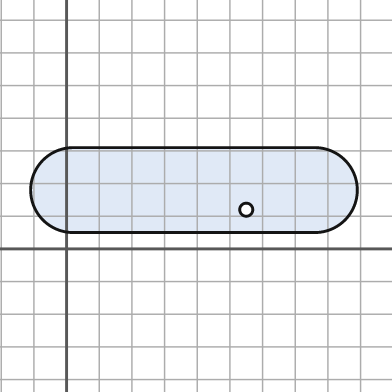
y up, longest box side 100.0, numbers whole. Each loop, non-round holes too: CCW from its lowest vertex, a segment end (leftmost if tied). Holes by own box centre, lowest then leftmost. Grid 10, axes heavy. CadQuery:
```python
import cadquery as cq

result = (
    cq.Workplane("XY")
    .moveTo(2.0, 5.0)
    .lineTo(76.0, 5.0)
    .threePointArc((89.0, 18.0), (76.0, 31.0))
    .lineTo(2.0, 31.0)
    .threePointArc((-11.0, 18.0), (2.0, 5.0))
    .close()
    .moveTo(55.0, 12.0)
    .circle(2.0)
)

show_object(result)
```